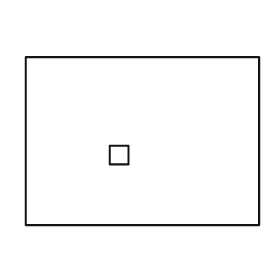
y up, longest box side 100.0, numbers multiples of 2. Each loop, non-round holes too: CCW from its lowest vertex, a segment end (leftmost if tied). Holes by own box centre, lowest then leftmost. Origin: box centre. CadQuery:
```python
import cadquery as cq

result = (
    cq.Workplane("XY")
    .moveTo(-50.0, -36.0)
    .lineTo(50.0, -36.0)
    .lineTo(50.0, 36.0)
    .lineTo(-50.0, 36.0)
    .close()
    .moveTo(-14.0, -10.0)
    .lineTo(-6.0, -10.0)
    .lineTo(-6.0, -2.0)
    .lineTo(-14.0, -2.0)
    .close()
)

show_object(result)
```